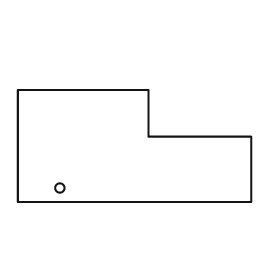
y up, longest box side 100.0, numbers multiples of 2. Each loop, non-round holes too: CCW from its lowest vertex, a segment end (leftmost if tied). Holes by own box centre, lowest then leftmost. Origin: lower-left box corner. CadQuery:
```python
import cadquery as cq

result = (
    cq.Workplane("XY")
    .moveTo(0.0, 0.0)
    .lineTo(100.0, 0.0)
    .lineTo(100.0, 28.0)
    .lineTo(56.0, 28.0)
    .lineTo(56.0, 48.0)
    .lineTo(0.0, 48.0)
    .close()
    .moveTo(18.0, 6.0)
    .circle(2.0)
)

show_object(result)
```